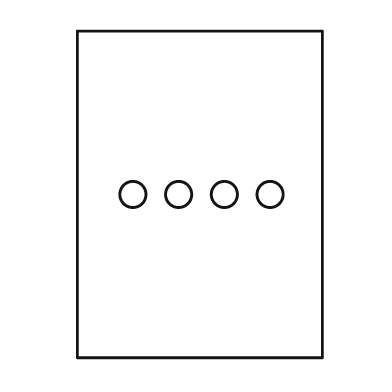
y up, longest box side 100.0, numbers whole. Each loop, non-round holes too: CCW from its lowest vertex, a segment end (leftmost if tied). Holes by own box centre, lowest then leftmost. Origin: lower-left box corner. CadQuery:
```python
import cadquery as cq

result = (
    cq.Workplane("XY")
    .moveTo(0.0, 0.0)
    .lineTo(75.0, 0.0)
    .lineTo(75.0, 100.0)
    .lineTo(0.0, 100.0)
    .close()
    .moveTo(17.0, 50.0)
    .circle(4.0)
    .moveTo(31.0, 50.0)
    .circle(4.0)
    .moveTo(45.0, 50.0)
    .circle(4.0)
    .moveTo(59.0, 50.0)
    .circle(4.0)
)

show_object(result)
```